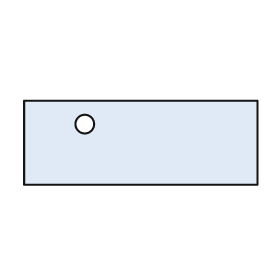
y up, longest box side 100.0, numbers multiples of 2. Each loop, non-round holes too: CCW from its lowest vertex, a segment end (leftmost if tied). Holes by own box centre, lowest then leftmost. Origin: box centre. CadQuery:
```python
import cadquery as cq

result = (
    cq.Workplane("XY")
    .moveTo(-50.0, -18.0)
    .lineTo(50.0, -18.0)
    .lineTo(50.0, 18.0)
    .lineTo(-50.0, 18.0)
    .close()
    .moveTo(-24.0, 8.0)
    .circle(4.0)
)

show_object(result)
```